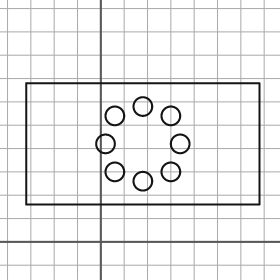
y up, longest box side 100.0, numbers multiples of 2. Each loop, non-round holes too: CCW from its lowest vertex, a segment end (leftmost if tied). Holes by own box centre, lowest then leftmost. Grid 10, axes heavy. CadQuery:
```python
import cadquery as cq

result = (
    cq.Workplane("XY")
    .moveTo(-32.0, 16.0)
    .lineTo(68.0, 16.0)
    .lineTo(68.0, 68.0)
    .lineTo(-32.0, 68.0)
    .close()
    .moveTo(18.0, 26.0)
    .circle(4.0)
    .moveTo(6.0, 30.0)
    .circle(4.0)
    .moveTo(30.0, 30.0)
    .circle(4.0)
    .moveTo(2.0, 42.0)
    .circle(4.0)
    .moveTo(34.0, 42.0)
    .circle(4.0)
    .moveTo(6.0, 54.0)
    .circle(4.0)
    .moveTo(30.0, 54.0)
    .circle(4.0)
    .moveTo(18.0, 58.0)
    .circle(4.0)
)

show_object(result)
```